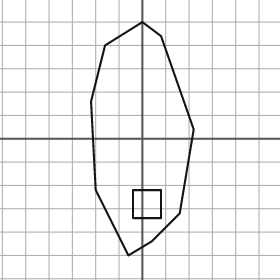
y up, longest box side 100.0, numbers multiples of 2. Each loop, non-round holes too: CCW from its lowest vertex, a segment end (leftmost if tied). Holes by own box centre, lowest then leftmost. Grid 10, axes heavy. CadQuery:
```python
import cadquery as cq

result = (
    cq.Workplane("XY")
    .moveTo(-6.0, -50.0)
    .lineTo(4.0, -44.0)
    .lineTo(16.0, -32.0)
    .lineTo(22.0, 4.0)
    .lineTo(8.0, 44.0)
    .lineTo(0.0, 50.0)
    .lineTo(-16.0, 40.0)
    .lineTo(-22.0, 16.0)
    .lineTo(-20.0, -22.0)
    .close()
    .moveTo(-4.0, -34.0)
    .lineTo(8.0, -34.0)
    .lineTo(8.0, -22.0)
    .lineTo(-4.0, -22.0)
    .close()
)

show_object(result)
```